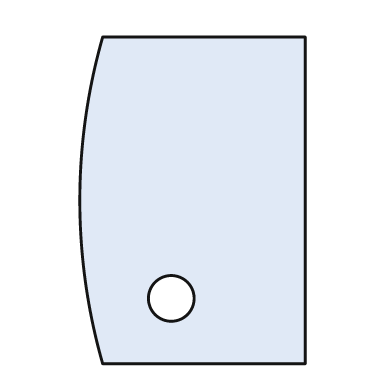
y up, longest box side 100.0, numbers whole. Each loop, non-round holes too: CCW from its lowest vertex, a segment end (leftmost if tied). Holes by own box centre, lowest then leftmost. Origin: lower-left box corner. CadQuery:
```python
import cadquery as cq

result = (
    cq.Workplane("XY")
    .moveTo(7.0, 0.0)
    .lineTo(69.0, 0.0)
    .lineTo(69.0, 100.0)
    .lineTo(7.0, 100.0)
    .threePointArc((0.0, 50.0), (7.0, 0.0))
    .close()
    .moveTo(28.0, 20.0)
    .circle(7.0)
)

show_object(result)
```